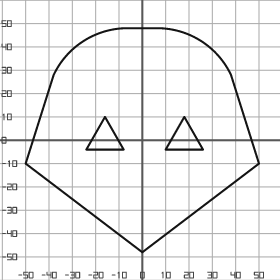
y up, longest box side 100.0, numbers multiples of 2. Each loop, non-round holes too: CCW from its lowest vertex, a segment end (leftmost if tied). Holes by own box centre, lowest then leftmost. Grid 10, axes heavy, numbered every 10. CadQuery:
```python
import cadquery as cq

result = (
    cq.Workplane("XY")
    .moveTo(0.0, -48.0)
    .lineTo(50.0, -10.0)
    .lineTo(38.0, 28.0)
    .threePointArc((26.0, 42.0), (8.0, 48.0))
    .lineTo(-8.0, 48.0)
    .threePointArc((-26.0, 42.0), (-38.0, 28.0))
    .lineTo(-50.0, -10.0)
    .close()
    .moveTo(-24.0, -4.0)
    .lineTo(-8.0, -4.0)
    .lineTo(-16.0, 10.0)
    .close()
    .moveTo(10.0, -4.0)
    .lineTo(26.0, -4.0)
    .lineTo(18.0, 10.0)
    .close()
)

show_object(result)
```